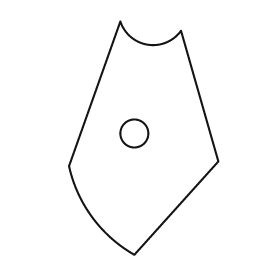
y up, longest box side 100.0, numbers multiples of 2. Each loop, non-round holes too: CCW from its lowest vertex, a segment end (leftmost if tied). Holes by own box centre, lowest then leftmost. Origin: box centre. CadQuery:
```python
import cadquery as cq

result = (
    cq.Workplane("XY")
    .moveTo(-4.0, -50.0)
    .lineTo(32.0, -10.0)
    .lineTo(16.0, 46.0)
    .threePointArc((2.0, 40.0), (-10.0, 50.0))
    .lineTo(-32.0, -12.0)
    .threePointArc((-22.0, -34.0), (-4.0, -50.0))
    .close()
    .moveTo(-4.0, 2.0)
    .circle(6.0)
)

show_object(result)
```